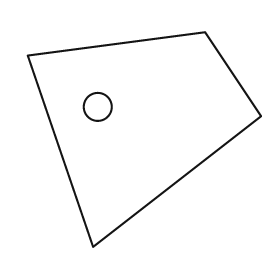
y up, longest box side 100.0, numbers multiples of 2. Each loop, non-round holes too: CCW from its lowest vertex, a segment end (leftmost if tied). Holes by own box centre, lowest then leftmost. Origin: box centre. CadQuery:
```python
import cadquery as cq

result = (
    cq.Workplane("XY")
    .moveTo(-22.0, -46.0)
    .lineTo(50.0, 10.0)
    .lineTo(26.0, 46.0)
    .lineTo(-50.0, 36.0)
    .close()
    .moveTo(-20.0, 14.0)
    .circle(6.0)
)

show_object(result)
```